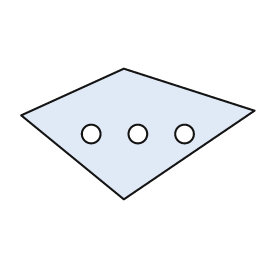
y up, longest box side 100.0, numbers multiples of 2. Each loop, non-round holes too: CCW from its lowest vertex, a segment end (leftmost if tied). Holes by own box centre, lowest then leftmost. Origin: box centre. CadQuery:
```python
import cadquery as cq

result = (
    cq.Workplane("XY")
    .moveTo(-6.0, -28.0)
    .lineTo(50.0, 10.0)
    .lineTo(-6.0, 28.0)
    .lineTo(-50.0, 8.0)
    .close()
    .moveTo(-20.0, 0.0)
    .circle(4.0)
    .moveTo(0.0, 0.0)
    .circle(4.0)
    .moveTo(20.0, 0.0)
    .circle(4.0)
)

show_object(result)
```